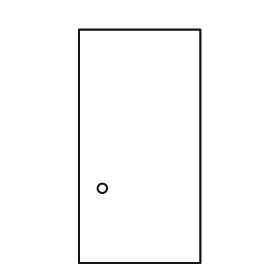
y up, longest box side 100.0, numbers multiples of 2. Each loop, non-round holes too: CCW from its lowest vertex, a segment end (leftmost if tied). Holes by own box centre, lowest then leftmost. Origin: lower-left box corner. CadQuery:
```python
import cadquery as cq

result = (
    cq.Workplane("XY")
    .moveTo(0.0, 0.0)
    .lineTo(52.0, 0.0)
    .lineTo(52.0, 100.0)
    .lineTo(0.0, 100.0)
    .close()
    .moveTo(10.0, 32.0)
    .circle(2.0)
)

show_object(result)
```